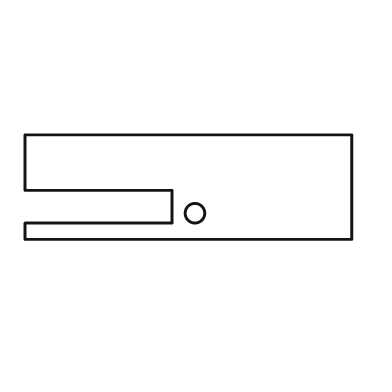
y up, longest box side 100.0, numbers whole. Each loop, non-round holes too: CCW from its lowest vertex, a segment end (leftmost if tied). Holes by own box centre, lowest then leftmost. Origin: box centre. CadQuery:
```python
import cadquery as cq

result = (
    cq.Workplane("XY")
    .moveTo(-50.0, -16.0)
    .lineTo(50.0, -16.0)
    .lineTo(50.0, 16.0)
    .lineTo(-50.0, 16.0)
    .lineTo(-50.0, -1.0)
    .lineTo(-5.0, -1.0)
    .lineTo(-5.0, -11.0)
    .lineTo(-50.0, -11.0)
    .close()
    .moveTo(2.0, -8.0)
    .circle(3.0)
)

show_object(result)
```